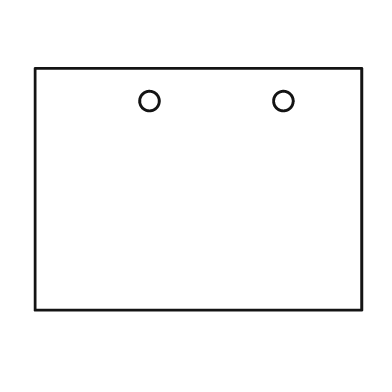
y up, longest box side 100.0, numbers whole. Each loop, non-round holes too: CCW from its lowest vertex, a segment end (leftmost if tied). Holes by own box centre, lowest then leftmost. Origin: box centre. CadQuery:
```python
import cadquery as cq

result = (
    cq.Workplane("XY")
    .moveTo(-50.0, -37.0)
    .lineTo(50.0, -37.0)
    .lineTo(50.0, 37.0)
    .lineTo(-50.0, 37.0)
    .close()
    .moveTo(-15.0, 27.0)
    .circle(3.0)
    .moveTo(26.0, 27.0)
    .circle(3.0)
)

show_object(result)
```